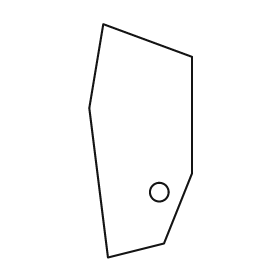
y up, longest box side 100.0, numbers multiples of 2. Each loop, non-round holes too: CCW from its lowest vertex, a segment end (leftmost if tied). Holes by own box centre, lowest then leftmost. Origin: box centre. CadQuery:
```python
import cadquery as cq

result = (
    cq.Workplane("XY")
    .moveTo(-14.0, -50.0)
    .lineTo(10.0, -44.0)
    .lineTo(22.0, -14.0)
    .lineTo(22.0, 36.0)
    .lineTo(-16.0, 50.0)
    .lineTo(-22.0, 14.0)
    .close()
    .moveTo(8.0, -22.0)
    .circle(4.0)
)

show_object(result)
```